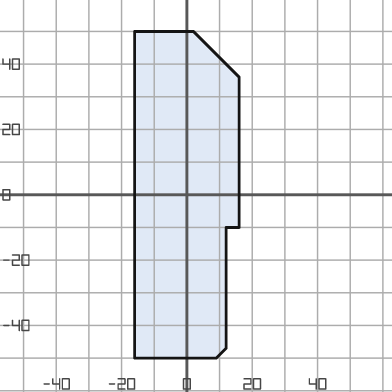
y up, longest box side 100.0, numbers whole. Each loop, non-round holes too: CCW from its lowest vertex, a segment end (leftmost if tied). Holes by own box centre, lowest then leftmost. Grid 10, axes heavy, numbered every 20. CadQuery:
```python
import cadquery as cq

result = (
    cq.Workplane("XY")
    .moveTo(-16.0, -50.0)
    .lineTo(9.0, -50.0)
    .lineTo(12.0, -47.0)
    .lineTo(12.0, -10.0)
    .lineTo(16.0, -10.0)
    .lineTo(16.0, 36.0)
    .lineTo(2.0, 50.0)
    .lineTo(-16.0, 50.0)
    .close()
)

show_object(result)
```